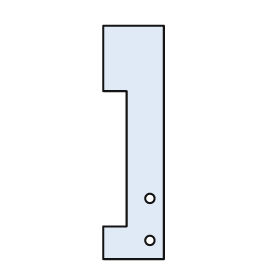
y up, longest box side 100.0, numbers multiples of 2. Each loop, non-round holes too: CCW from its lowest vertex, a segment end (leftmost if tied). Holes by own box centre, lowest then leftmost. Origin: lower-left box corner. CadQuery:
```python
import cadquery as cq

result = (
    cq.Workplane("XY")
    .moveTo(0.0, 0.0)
    .lineTo(26.0, 0.0)
    .lineTo(26.0, 100.0)
    .lineTo(0.0, 100.0)
    .lineTo(0.0, 72.0)
    .lineTo(10.0, 72.0)
    .lineTo(10.0, 14.0)
    .lineTo(0.0, 14.0)
    .close()
    .moveTo(20.0, 8.0)
    .circle(2.0)
    .moveTo(20.0, 26.0)
    .circle(2.0)
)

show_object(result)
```